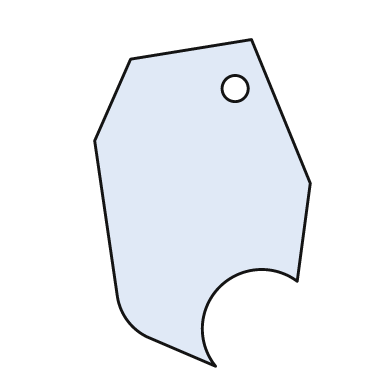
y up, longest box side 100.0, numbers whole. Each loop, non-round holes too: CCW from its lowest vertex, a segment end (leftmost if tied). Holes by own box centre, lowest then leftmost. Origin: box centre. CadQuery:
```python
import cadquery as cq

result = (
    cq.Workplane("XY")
    .moveTo(4.0, -50.0)
    .threePointArc((5.0, -26.0), (29.0, -24.0))
    .lineTo(33.0, 6.0)
    .lineTo(15.0, 50.0)
    .lineTo(-22.0, 44.0)
    .lineTo(-33.0, 19.0)
    .lineTo(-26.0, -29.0)
    .threePointArc((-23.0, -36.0), (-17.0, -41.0))
    .close()
    .moveTo(10.0, 35.0)
    .circle(4.0)
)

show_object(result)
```